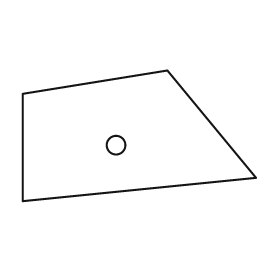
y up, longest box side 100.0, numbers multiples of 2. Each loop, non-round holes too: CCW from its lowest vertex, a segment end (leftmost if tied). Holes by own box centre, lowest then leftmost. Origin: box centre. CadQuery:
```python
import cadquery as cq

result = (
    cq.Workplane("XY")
    .moveTo(-50.0, -28.0)
    .lineTo(50.0, -18.0)
    .lineTo(12.0, 28.0)
    .lineTo(-50.0, 18.0)
    .close()
    .moveTo(-10.0, -4.0)
    .circle(4.0)
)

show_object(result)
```